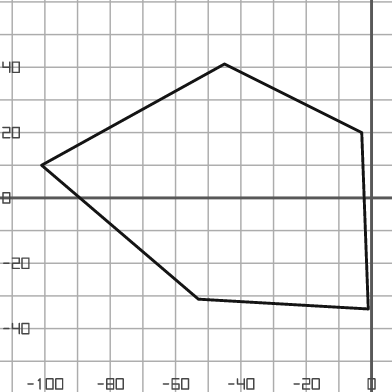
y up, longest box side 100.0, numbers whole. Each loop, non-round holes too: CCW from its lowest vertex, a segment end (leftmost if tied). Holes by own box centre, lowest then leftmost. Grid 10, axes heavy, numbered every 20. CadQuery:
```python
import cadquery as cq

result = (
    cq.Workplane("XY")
    .moveTo(-1.0, -34.0)
    .lineTo(-3.0, 20.0)
    .lineTo(-45.0, 41.0)
    .lineTo(-101.0, 10.0)
    .lineTo(-53.0, -31.0)
    .close()
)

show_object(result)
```